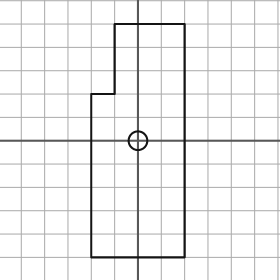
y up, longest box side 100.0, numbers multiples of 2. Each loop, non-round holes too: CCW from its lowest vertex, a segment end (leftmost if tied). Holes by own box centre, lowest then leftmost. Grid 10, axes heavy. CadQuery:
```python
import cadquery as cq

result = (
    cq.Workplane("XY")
    .moveTo(-20.0, -50.0)
    .lineTo(20.0, -50.0)
    .lineTo(20.0, 50.0)
    .lineTo(-10.0, 50.0)
    .lineTo(-10.0, 20.0)
    .lineTo(-20.0, 20.0)
    .close()
    .moveTo(0.0, 0.0)
    .circle(4.0)
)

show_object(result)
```